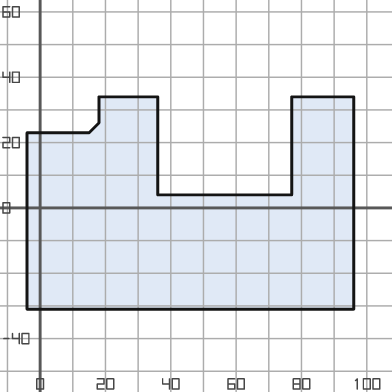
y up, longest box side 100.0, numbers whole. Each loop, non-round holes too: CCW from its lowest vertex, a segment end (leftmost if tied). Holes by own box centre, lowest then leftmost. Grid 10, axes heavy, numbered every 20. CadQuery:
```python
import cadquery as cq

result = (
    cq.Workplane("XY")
    .moveTo(-4.0, -31.0)
    .lineTo(96.0, -31.0)
    .lineTo(96.0, 34.0)
    .lineTo(77.0, 34.0)
    .lineTo(77.0, 4.0)
    .lineTo(36.0, 4.0)
    .lineTo(36.0, 34.0)
    .lineTo(18.0, 34.0)
    .lineTo(18.0, 26.0)
    .lineTo(15.0, 23.0)
    .lineTo(-4.0, 23.0)
    .close()
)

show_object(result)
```